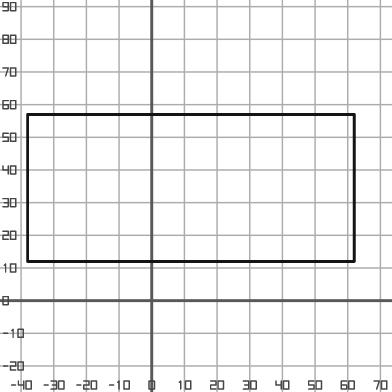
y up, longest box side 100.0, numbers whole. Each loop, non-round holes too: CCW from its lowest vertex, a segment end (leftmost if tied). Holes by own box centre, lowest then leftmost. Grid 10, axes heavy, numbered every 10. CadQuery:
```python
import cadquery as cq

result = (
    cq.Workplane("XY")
    .moveTo(-38.0, 12.0)
    .lineTo(62.0, 12.0)
    .lineTo(62.0, 57.0)
    .lineTo(-38.0, 57.0)
    .close()
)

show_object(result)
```